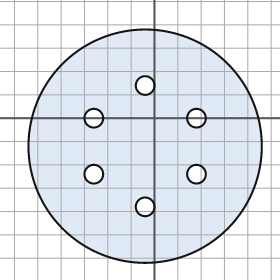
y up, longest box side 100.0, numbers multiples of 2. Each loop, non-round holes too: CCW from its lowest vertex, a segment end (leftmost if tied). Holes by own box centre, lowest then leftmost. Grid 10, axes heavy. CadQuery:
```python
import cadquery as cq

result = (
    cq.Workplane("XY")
    .moveTo(-4.0, -12.0)
    .circle(50.0)
    .moveTo(-4.0, -38.0)
    .circle(4.0)
    .moveTo(-26.0, -24.0)
    .circle(4.0)
    .moveTo(18.0, -24.0)
    .circle(4.0)
    .moveTo(-26.0, 0.0)
    .circle(4.0)
    .moveTo(18.0, 0.0)
    .circle(4.0)
    .moveTo(-4.0, 14.0)
    .circle(4.0)
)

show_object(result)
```